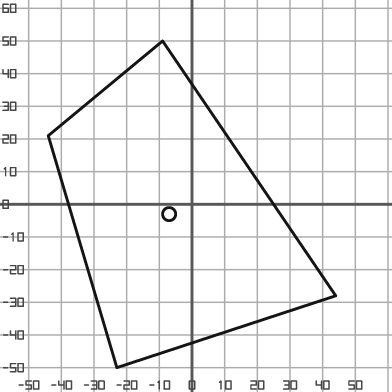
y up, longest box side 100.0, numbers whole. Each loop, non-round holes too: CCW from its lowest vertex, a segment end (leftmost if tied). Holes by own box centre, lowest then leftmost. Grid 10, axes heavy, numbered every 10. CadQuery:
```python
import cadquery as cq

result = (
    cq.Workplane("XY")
    .moveTo(-23.0, -50.0)
    .lineTo(44.0, -28.0)
    .lineTo(-9.0, 50.0)
    .lineTo(-44.0, 21.0)
    .close()
    .moveTo(-7.0, -3.0)
    .circle(2.0)
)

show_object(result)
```